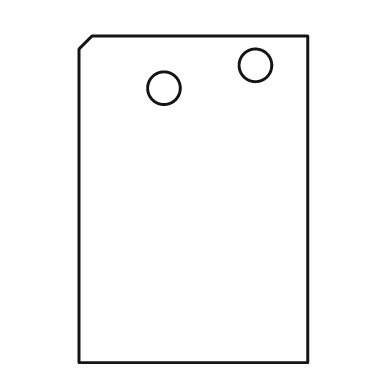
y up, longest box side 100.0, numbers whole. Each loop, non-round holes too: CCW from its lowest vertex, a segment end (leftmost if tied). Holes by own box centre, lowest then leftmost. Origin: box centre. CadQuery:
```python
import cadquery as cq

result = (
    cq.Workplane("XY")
    .moveTo(-35.0, -50.0)
    .lineTo(35.0, -50.0)
    .lineTo(35.0, 50.0)
    .lineTo(-31.0, 50.0)
    .lineTo(-35.0, 46.0)
    .close()
    .moveTo(-9.0, 34.0)
    .circle(5.0)
    .moveTo(19.0, 41.0)
    .circle(5.0)
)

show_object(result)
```